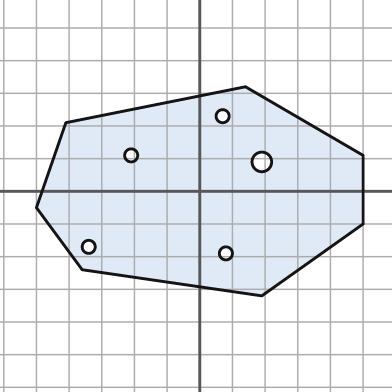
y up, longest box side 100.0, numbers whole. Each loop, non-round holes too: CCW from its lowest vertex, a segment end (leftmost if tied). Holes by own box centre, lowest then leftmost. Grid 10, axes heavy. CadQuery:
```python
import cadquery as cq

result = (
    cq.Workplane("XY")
    .moveTo(19.0, -32.0)
    .lineTo(50.0, -10.0)
    .lineTo(50.0, 11.0)
    .lineTo(14.0, 32.0)
    .lineTo(-41.0, 21.0)
    .lineTo(-50.0, -5.0)
    .lineTo(-36.0, -24.0)
    .close()
    .moveTo(8.0, -19.0)
    .circle(2.0)
    .moveTo(-34.0, -17.0)
    .circle(2.0)
    .moveTo(19.0, 9.0)
    .circle(3.0)
    .moveTo(-21.0, 11.0)
    .circle(2.0)
    .moveTo(7.0, 23.0)
    .circle(2.0)
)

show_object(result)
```